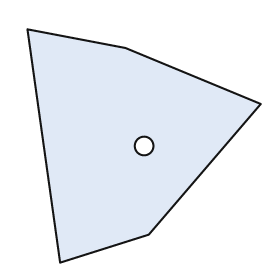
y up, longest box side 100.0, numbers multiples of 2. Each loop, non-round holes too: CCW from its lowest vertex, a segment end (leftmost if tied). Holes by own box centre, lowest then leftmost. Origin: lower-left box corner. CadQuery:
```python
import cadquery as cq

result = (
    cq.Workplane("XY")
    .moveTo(14.0, 0.0)
    .lineTo(52.0, 12.0)
    .lineTo(100.0, 68.0)
    .lineTo(42.0, 92.0)
    .lineTo(0.0, 100.0)
    .close()
    .moveTo(50.0, 50.0)
    .circle(4.0)
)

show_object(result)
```